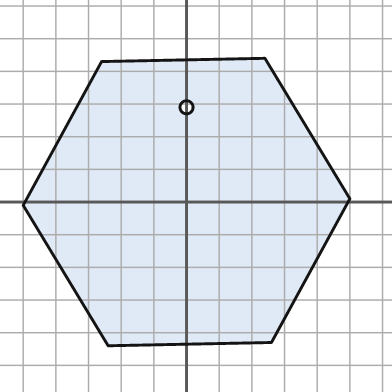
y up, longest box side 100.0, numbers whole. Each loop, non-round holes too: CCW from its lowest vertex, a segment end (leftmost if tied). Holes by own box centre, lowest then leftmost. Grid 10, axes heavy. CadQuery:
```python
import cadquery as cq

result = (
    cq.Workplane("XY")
    .moveTo(-24.0, -44.0)
    .lineTo(26.0, -43.0)
    .lineTo(50.0, 1.0)
    .lineTo(24.0, 44.0)
    .lineTo(-26.0, 43.0)
    .lineTo(-50.0, -1.0)
    .close()
    .moveTo(0.0, 29.0)
    .circle(2.0)
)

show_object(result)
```